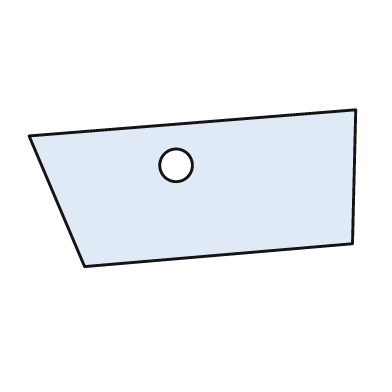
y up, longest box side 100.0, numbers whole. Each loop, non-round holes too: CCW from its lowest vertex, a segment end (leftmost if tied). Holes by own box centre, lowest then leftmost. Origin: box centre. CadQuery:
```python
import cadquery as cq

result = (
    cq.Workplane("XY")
    .moveTo(-33.0, -24.0)
    .lineTo(49.0, -17.0)
    .lineTo(50.0, 24.0)
    .lineTo(-50.0, 16.0)
    .close()
    .moveTo(-5.0, 7.0)
    .circle(5.0)
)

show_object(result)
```